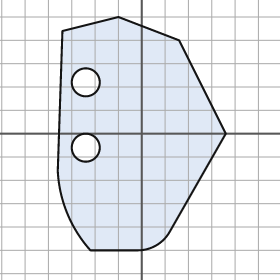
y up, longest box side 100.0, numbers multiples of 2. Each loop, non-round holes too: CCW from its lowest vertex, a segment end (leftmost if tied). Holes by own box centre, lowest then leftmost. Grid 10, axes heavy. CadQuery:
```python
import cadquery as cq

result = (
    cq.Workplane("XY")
    .moveTo(-22.0, -50.0)
    .lineTo(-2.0, -50.0)
    .threePointArc((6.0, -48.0), (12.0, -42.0))
    .lineTo(36.0, 0.0)
    .lineTo(16.0, 40.0)
    .lineTo(-10.0, 50.0)
    .lineTo(-34.0, 44.0)
    .lineTo(-36.0, -16.0)
    .threePointArc((-32.0, -34.0), (-22.0, -50.0))
    .close()
    .moveTo(-24.0, -6.0)
    .circle(6.0)
    .moveTo(-24.0, 22.0)
    .circle(6.0)
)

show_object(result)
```